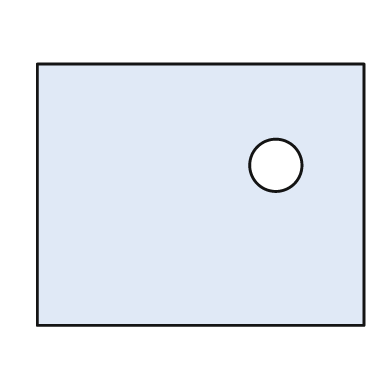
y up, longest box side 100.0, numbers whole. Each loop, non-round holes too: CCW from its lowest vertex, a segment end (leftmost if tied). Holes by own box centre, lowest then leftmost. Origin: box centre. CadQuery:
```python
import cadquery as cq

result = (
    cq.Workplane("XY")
    .moveTo(-50.0, -40.0)
    .lineTo(50.0, -40.0)
    .lineTo(50.0, 40.0)
    .lineTo(-50.0, 40.0)
    .close()
    .moveTo(23.0, 9.0)
    .circle(8.0)
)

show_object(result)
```